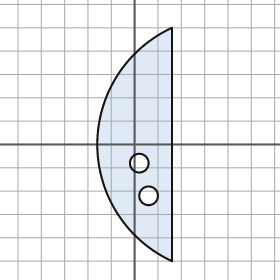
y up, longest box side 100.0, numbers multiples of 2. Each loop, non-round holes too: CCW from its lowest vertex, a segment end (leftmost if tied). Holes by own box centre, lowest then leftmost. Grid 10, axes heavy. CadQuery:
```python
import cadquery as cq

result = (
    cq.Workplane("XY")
    .moveTo(16.0, -50.0)
    .lineTo(16.0, 50.0)
    .threePointArc((-16.0, 0.0), (16.0, -50.0))
    .close()
    .moveTo(6.0, -22.0)
    .circle(4.0)
    .moveTo(2.0, -8.0)
    .circle(4.0)
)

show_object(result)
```